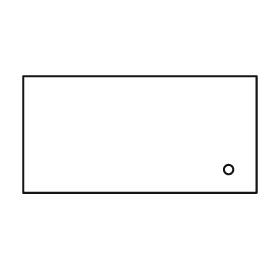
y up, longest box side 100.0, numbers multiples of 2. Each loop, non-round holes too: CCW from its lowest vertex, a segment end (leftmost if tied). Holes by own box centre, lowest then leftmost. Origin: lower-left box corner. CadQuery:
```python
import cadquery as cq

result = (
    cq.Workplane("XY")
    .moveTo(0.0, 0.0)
    .lineTo(100.0, 0.0)
    .lineTo(100.0, 50.0)
    .lineTo(0.0, 50.0)
    .close()
    .moveTo(88.0, 10.0)
    .circle(2.0)
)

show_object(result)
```